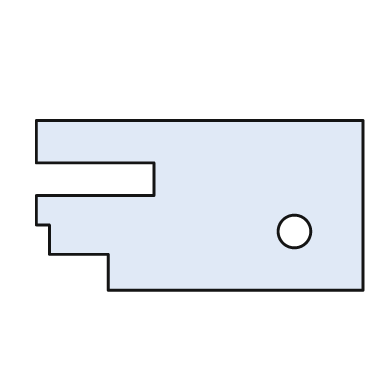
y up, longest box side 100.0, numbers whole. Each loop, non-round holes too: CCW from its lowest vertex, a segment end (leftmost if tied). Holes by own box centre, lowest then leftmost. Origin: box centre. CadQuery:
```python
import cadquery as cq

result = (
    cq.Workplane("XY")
    .moveTo(-28.0, -26.0)
    .lineTo(50.0, -26.0)
    .lineTo(50.0, 26.0)
    .lineTo(-50.0, 26.0)
    .lineTo(-50.0, 13.0)
    .lineTo(-14.0, 13.0)
    .lineTo(-14.0, 3.0)
    .lineTo(-50.0, 3.0)
    .lineTo(-50.0, -6.0)
    .lineTo(-46.0, -6.0)
    .lineTo(-46.0, -15.0)
    .lineTo(-28.0, -15.0)
    .close()
    .moveTo(29.0, -8.0)
    .circle(5.0)
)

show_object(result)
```